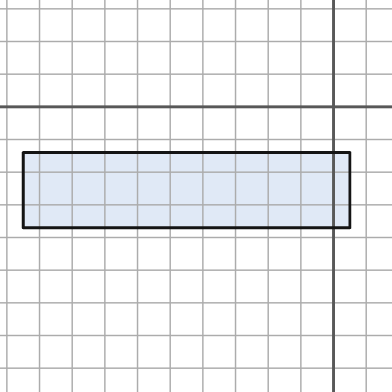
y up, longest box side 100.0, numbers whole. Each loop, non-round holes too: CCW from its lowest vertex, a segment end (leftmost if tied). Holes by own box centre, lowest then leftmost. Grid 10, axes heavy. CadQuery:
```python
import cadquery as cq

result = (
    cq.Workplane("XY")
    .moveTo(-95.0, -37.0)
    .lineTo(5.0, -37.0)
    .lineTo(5.0, -14.0)
    .lineTo(-95.0, -14.0)
    .close()
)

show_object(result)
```